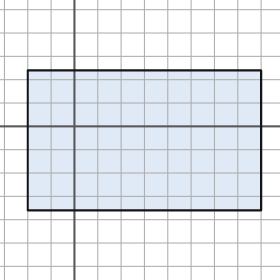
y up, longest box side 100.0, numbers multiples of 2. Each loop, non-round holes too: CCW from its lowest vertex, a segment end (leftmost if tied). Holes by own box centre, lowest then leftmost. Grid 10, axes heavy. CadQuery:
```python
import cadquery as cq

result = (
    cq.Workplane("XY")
    .moveTo(-20.0, -36.0)
    .lineTo(80.0, -36.0)
    .lineTo(80.0, 24.0)
    .lineTo(-20.0, 24.0)
    .close()
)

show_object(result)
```